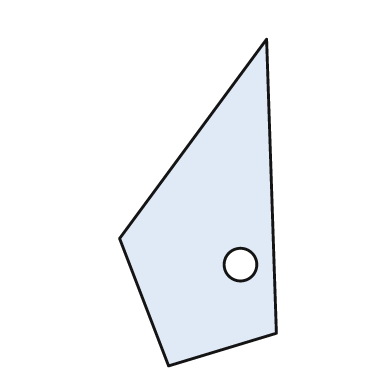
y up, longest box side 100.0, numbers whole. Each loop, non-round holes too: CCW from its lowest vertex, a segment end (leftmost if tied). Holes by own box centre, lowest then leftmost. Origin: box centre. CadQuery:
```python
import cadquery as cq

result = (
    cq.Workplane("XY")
    .moveTo(-9.0, -50.0)
    .lineTo(24.0, -40.0)
    .lineTo(21.0, 50.0)
    .lineTo(-24.0, -11.0)
    .close()
    .moveTo(13.0, -19.0)
    .circle(5.0)
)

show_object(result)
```